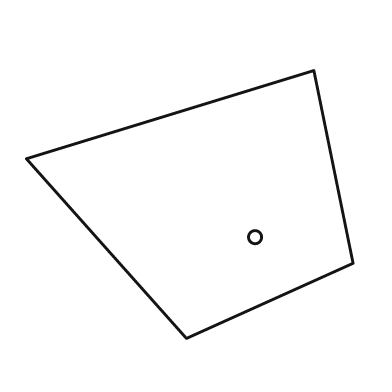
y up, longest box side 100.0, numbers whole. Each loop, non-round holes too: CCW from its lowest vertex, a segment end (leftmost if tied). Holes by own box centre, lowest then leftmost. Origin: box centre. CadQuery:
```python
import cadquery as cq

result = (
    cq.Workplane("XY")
    .moveTo(-1.0, -41.0)
    .lineTo(50.0, -18.0)
    .lineTo(38.0, 41.0)
    .lineTo(-50.0, 14.0)
    .close()
    .moveTo(20.0, -10.0)
    .circle(2.0)
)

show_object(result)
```